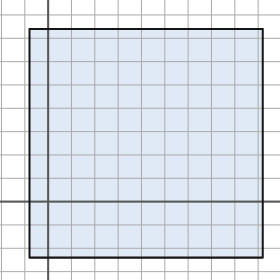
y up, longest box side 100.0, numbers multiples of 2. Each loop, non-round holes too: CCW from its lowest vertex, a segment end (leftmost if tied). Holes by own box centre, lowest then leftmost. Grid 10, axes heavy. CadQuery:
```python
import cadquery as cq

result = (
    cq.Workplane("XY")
    .moveTo(-8.0, -24.0)
    .lineTo(92.0, -24.0)
    .lineTo(92.0, 74.0)
    .lineTo(-8.0, 74.0)
    .close()
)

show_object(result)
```